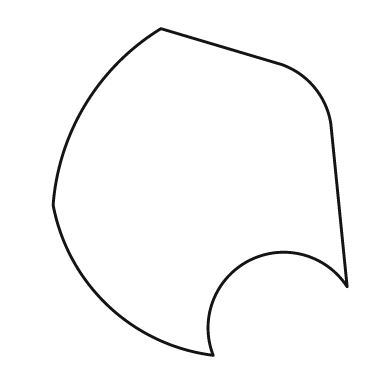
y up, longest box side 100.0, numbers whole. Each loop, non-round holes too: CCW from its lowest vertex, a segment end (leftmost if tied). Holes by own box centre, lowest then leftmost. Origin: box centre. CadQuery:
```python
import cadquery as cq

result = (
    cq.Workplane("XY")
    .moveTo(4.0, -50.0)
    .threePointArc((15.0, -21.0), (45.0, -29.0))
    .lineTo(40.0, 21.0)
    .threePointArc((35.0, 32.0), (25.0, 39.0))
    .lineTo(-12.0, 50.0)
    .threePointArc((-35.0, 27.0), (-45.0, -4.0))
    .threePointArc((-28.0, -35.0), (4.0, -50.0))
    .close()
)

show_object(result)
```